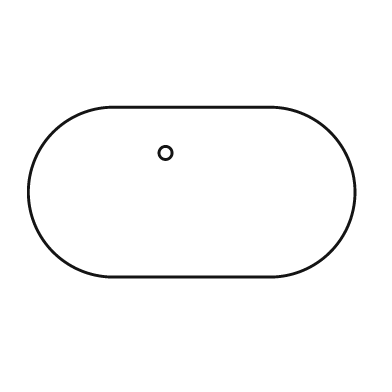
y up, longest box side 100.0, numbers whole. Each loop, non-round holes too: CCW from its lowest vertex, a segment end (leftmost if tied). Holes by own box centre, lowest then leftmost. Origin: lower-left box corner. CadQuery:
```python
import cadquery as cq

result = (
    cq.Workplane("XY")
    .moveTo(26.0, 0.0)
    .lineTo(74.0, 0.0)
    .threePointArc((100.0, 26.0), (74.0, 52.0))
    .lineTo(26.0, 52.0)
    .threePointArc((0.0, 26.0), (26.0, 0.0))
    .close()
    .moveTo(42.0, 38.0)
    .circle(2.0)
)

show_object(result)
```